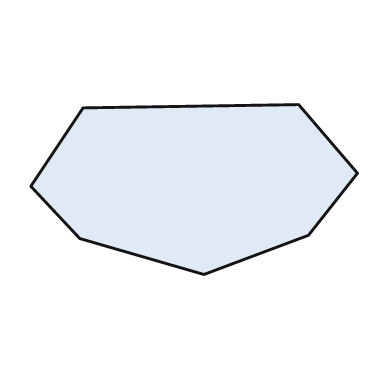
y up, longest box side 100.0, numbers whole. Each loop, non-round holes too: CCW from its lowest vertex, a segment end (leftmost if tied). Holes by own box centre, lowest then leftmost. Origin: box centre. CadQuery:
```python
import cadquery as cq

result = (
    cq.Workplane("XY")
    .moveTo(3.0, -26.0)
    .lineTo(35.0, -14.0)
    .lineTo(50.0, 5.0)
    .lineTo(32.0, 26.0)
    .lineTo(-34.0, 25.0)
    .lineTo(-50.0, 1.0)
    .lineTo(-35.0, -15.0)
    .close()
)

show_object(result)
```